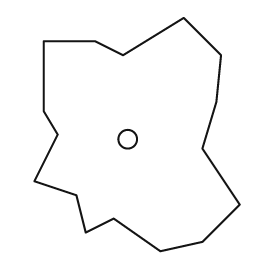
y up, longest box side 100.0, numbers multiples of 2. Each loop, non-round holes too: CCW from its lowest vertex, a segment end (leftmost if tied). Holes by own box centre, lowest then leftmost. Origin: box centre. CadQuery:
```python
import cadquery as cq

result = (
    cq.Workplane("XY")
    .moveTo(10.0, -50.0)
    .lineTo(28.0, -46.0)
    .lineTo(44.0, -30.0)
    .lineTo(28.0, -6.0)
    .lineTo(34.0, 14.0)
    .lineTo(36.0, 34.0)
    .lineTo(20.0, 50.0)
    .lineTo(-6.0, 34.0)
    .lineTo(-18.0, 40.0)
    .lineTo(-40.0, 40.0)
    .lineTo(-40.0, 10.0)
    .lineTo(-34.0, 0.0)
    .lineTo(-44.0, -20.0)
    .lineTo(-26.0, -26.0)
    .lineTo(-22.0, -42.0)
    .lineTo(-10.0, -36.0)
    .close()
    .moveTo(-4.0, -2.0)
    .circle(4.0)
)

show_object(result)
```